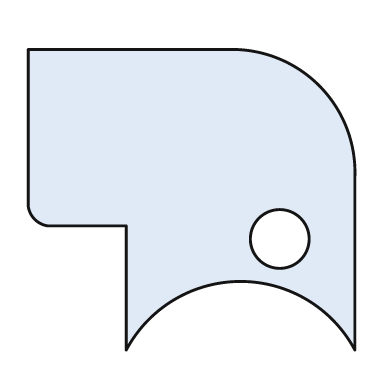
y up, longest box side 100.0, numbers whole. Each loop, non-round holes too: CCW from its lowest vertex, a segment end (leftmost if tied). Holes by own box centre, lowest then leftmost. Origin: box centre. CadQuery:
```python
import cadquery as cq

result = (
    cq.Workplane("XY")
    .moveTo(-20.0, -46.0)
    .threePointArc((15.0, -25.0), (50.0, -46.0))
    .lineTo(50.0, 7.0)
    .threePointArc((39.0, 35.0), (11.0, 46.0))
    .lineTo(-50.0, 46.0)
    .lineTo(-50.0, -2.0)
    .threePointArc((-48.0, -6.0), (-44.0, -8.0))
    .lineTo(-20.0, -8.0)
    .close()
    .moveTo(27.0, -12.0)
    .circle(9.0)
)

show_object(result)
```